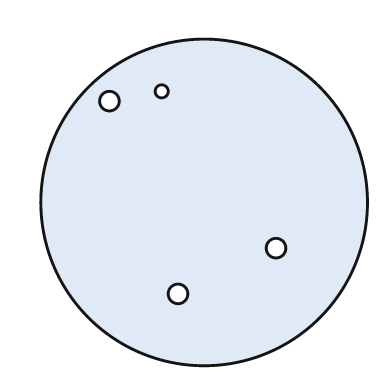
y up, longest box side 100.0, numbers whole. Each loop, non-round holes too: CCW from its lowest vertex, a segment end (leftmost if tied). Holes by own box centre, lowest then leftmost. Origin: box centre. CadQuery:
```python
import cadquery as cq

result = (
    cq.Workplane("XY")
    .moveTo(0.0, 0.0)
    .circle(50.0)
    .moveTo(-8.0, -28.0)
    .circle(3.0)
    .moveTo(22.0, -14.0)
    .circle(3.0)
    .moveTo(-29.0, 31.0)
    .circle(3.0)
    .moveTo(-13.0, 34.0)
    .circle(2.0)
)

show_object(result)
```